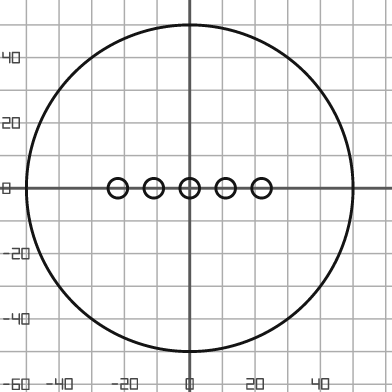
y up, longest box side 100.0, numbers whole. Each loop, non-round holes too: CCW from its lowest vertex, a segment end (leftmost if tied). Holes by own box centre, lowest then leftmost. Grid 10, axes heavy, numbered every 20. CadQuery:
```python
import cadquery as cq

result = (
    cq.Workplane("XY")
    .moveTo(0.0, 0.0)
    .circle(50.0)
    .moveTo(-22.0, 0.0)
    .circle(3.0)
    .moveTo(-11.0, 0.0)
    .circle(3.0)
    .moveTo(0.0, 0.0)
    .circle(3.0)
    .moveTo(11.0, 0.0)
    .circle(3.0)
    .moveTo(22.0, 0.0)
    .circle(3.0)
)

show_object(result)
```